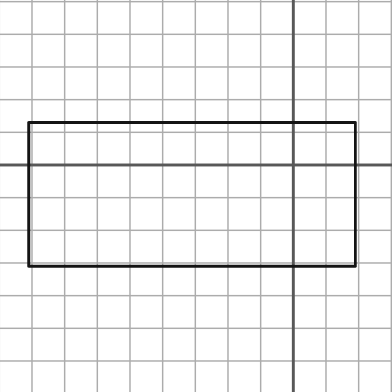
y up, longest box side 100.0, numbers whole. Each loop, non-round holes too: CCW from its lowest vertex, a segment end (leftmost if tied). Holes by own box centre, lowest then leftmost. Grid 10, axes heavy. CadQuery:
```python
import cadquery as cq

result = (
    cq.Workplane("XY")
    .moveTo(-81.0, -31.0)
    .lineTo(19.0, -31.0)
    .lineTo(19.0, 13.0)
    .lineTo(-81.0, 13.0)
    .close()
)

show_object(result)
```